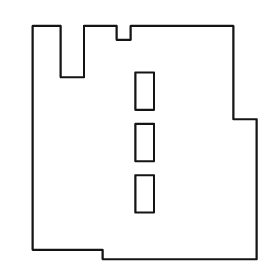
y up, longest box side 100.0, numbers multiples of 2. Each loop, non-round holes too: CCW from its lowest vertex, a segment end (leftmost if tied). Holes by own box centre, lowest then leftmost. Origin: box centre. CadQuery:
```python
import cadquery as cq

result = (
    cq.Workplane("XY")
    .moveTo(-18.0, -50.0)
    .lineTo(48.0, -50.0)
    .lineTo(48.0, 10.0)
    .lineTo(38.0, 10.0)
    .lineTo(38.0, 50.0)
    .lineTo(-6.0, 50.0)
    .lineTo(-6.0, 44.0)
    .lineTo(-12.0, 44.0)
    .lineTo(-12.0, 50.0)
    .lineTo(-26.0, 50.0)
    .lineTo(-26.0, 28.0)
    .lineTo(-36.0, 28.0)
    .lineTo(-36.0, 50.0)
    .lineTo(-48.0, 50.0)
    .lineTo(-48.0, -46.0)
    .lineTo(-18.0, -46.0)
    .close()
    .moveTo(-4.0, -30.0)
    .lineTo(4.0, -30.0)
    .lineTo(4.0, -14.0)
    .lineTo(-4.0, -14.0)
    .close()
    .moveTo(-4.0, -8.0)
    .lineTo(4.0, -8.0)
    .lineTo(4.0, 8.0)
    .lineTo(-4.0, 8.0)
    .close()
    .moveTo(-4.0, 14.0)
    .lineTo(4.0, 14.0)
    .lineTo(4.0, 30.0)
    .lineTo(-4.0, 30.0)
    .close()
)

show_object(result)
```